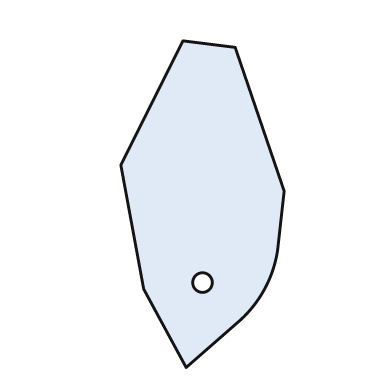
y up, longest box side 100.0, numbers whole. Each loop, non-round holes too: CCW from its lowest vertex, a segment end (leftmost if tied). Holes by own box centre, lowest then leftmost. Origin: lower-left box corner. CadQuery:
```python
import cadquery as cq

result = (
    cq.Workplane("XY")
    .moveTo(20.0, 0.0)
    .lineTo(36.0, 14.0)
    .threePointArc((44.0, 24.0), (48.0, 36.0))
    .lineTo(50.0, 54.0)
    .lineTo(35.0, 98.0)
    .lineTo(19.0, 100.0)
    .lineTo(0.0, 62.0)
    .lineTo(7.0, 24.0)
    .close()
    .moveTo(25.0, 26.0)
    .circle(3.0)
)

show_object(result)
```